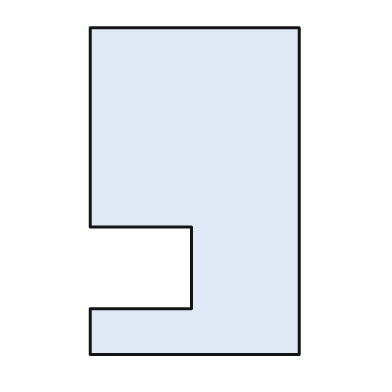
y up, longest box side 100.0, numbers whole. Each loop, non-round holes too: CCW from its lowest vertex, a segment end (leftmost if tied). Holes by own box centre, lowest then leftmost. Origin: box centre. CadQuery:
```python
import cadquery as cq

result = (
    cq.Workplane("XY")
    .moveTo(-32.0, -50.0)
    .lineTo(32.0, -50.0)
    .lineTo(32.0, 50.0)
    .lineTo(-32.0, 50.0)
    .lineTo(-32.0, -11.0)
    .lineTo(-1.0, -11.0)
    .lineTo(-1.0, -36.0)
    .lineTo(-32.0, -36.0)
    .close()
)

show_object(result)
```